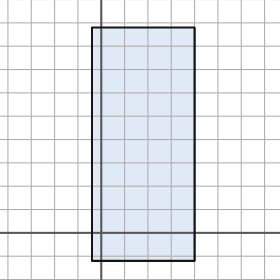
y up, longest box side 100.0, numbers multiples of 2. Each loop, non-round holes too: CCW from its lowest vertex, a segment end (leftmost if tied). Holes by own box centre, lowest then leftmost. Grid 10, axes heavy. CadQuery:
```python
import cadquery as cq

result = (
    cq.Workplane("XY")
    .moveTo(-4.0, -12.0)
    .lineTo(40.0, -12.0)
    .lineTo(40.0, 88.0)
    .lineTo(-4.0, 88.0)
    .close()
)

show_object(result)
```